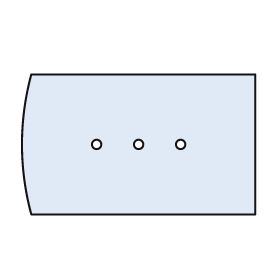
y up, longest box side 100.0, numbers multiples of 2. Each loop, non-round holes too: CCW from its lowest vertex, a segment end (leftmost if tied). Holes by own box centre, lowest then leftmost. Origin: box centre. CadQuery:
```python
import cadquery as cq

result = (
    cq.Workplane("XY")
    .moveTo(-46.0, -30.0)
    .lineTo(50.0, -30.0)
    .lineTo(50.0, 30.0)
    .lineTo(-46.0, 30.0)
    .threePointArc((-50.0, 0.0), (-46.0, -30.0))
    .close()
    .moveTo(-18.0, 0.0)
    .circle(2.0)
    .moveTo(0.0, 0.0)
    .circle(2.0)
    .moveTo(18.0, 0.0)
    .circle(2.0)
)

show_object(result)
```